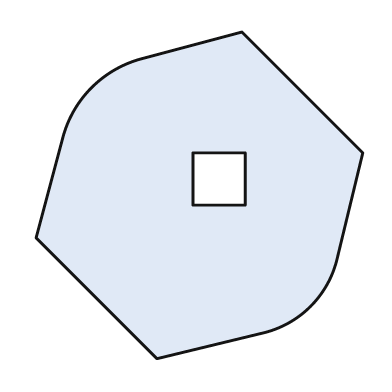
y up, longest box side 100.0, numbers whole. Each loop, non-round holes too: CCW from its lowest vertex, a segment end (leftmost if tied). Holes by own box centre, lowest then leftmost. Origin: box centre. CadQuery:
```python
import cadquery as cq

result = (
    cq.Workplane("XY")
    .moveTo(-13.0, -50.0)
    .lineTo(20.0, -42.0)
    .threePointArc((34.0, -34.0), (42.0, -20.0))
    .lineTo(50.0, 13.0)
    .lineTo(13.0, 50.0)
    .lineTo(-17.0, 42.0)
    .threePointArc((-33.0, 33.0), (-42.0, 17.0))
    .lineTo(-50.0, -13.0)
    .close()
    .moveTo(-2.0, -3.0)
    .lineTo(14.0, -3.0)
    .lineTo(14.0, 13.0)
    .lineTo(-2.0, 13.0)
    .close()
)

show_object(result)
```